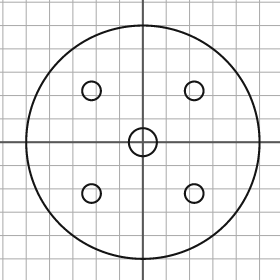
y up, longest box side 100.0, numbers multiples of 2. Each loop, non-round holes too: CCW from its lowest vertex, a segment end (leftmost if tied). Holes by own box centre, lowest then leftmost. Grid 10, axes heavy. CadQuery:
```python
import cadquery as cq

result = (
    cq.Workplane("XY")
    .moveTo(0.0, 0.0)
    .circle(50.0)
    .moveTo(-22.0, -22.0)
    .circle(4.0)
    .moveTo(22.0, -22.0)
    .circle(4.0)
    .moveTo(0.0, 0.0)
    .circle(6.0)
    .moveTo(-22.0, 22.0)
    .circle(4.0)
    .moveTo(22.0, 22.0)
    .circle(4.0)
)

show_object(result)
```